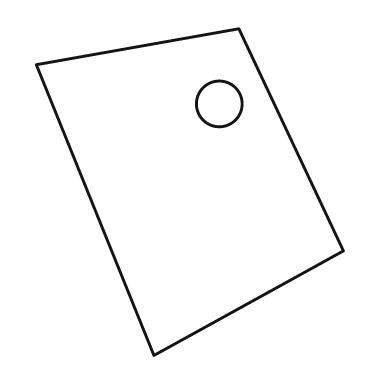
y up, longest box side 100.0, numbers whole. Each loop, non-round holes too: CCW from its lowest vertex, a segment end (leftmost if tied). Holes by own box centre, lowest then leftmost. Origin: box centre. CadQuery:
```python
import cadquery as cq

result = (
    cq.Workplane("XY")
    .moveTo(-11.0, -50.0)
    .lineTo(47.0, -18.0)
    .lineTo(15.0, 50.0)
    .lineTo(-47.0, 39.0)
    .close()
    .moveTo(9.0, 27.0)
    .circle(7.0)
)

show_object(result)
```